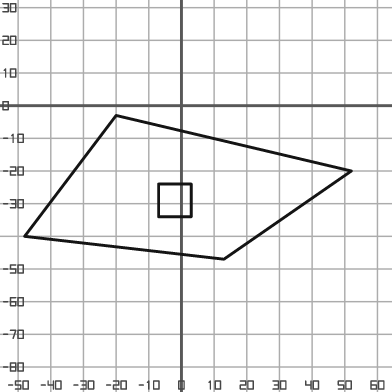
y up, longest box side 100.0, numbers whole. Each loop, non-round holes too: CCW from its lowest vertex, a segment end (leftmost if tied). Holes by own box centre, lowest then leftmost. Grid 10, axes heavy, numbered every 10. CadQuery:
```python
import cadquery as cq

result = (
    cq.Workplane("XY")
    .moveTo(13.0, -47.0)
    .lineTo(52.0, -20.0)
    .lineTo(-20.0, -3.0)
    .lineTo(-48.0, -40.0)
    .close()
    .moveTo(-7.0, -34.0)
    .lineTo(3.0, -34.0)
    .lineTo(3.0, -24.0)
    .lineTo(-7.0, -24.0)
    .close()
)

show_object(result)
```